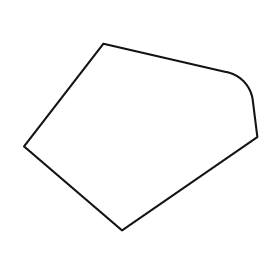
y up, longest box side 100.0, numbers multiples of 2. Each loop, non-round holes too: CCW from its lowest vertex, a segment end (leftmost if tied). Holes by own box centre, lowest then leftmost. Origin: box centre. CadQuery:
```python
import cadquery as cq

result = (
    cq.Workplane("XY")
    .moveTo(-8.0, -40.0)
    .lineTo(50.0, 0.0)
    .lineTo(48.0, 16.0)
    .threePointArc((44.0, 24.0), (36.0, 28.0))
    .lineTo(-16.0, 40.0)
    .lineTo(-50.0, -4.0)
    .close()
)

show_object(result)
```